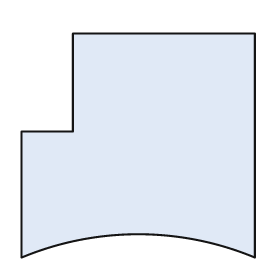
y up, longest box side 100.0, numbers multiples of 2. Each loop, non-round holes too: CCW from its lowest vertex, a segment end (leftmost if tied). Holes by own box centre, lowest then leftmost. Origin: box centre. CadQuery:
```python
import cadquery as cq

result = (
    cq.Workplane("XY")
    .moveTo(-50.0, -48.0)
    .threePointArc((0.0, -38.0), (50.0, -48.0))
    .lineTo(50.0, 48.0)
    .lineTo(-28.0, 48.0)
    .lineTo(-28.0, 6.0)
    .lineTo(-50.0, 6.0)
    .close()
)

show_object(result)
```